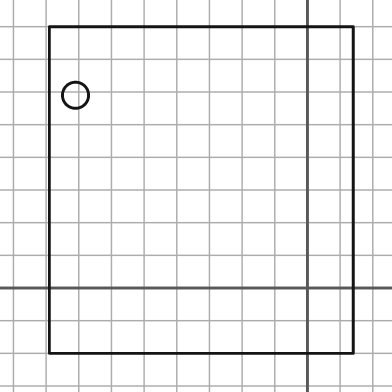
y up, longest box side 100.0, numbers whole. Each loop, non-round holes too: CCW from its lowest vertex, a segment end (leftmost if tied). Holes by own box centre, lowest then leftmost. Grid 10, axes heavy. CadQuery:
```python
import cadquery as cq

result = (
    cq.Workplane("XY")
    .moveTo(-79.0, -20.0)
    .lineTo(14.0, -20.0)
    .lineTo(14.0, 80.0)
    .lineTo(-79.0, 80.0)
    .close()
    .moveTo(-71.0, 59.0)
    .circle(4.0)
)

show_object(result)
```